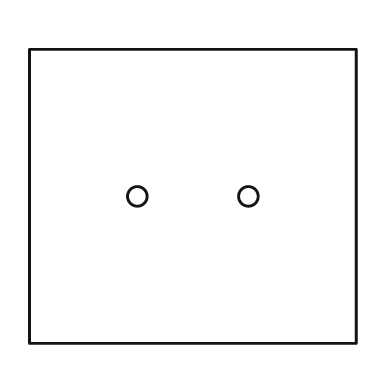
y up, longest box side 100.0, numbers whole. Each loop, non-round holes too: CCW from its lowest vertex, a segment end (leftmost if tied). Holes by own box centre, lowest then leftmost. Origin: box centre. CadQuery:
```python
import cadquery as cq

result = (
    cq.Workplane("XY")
    .moveTo(-50.0, -45.0)
    .lineTo(50.0, -45.0)
    .lineTo(50.0, 45.0)
    .lineTo(-50.0, 45.0)
    .close()
    .moveTo(-17.0, 0.0)
    .circle(3.0)
    .moveTo(17.0, 0.0)
    .circle(3.0)
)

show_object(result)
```